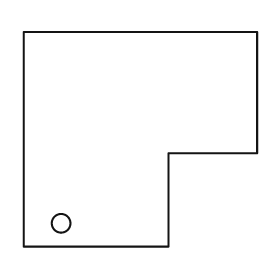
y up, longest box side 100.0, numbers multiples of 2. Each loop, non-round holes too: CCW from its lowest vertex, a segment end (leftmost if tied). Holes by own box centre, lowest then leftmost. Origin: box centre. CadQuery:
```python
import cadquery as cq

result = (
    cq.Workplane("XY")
    .moveTo(-50.0, -46.0)
    .lineTo(12.0, -46.0)
    .lineTo(12.0, -6.0)
    .lineTo(50.0, -6.0)
    .lineTo(50.0, 46.0)
    .lineTo(-50.0, 46.0)
    .close()
    .moveTo(-34.0, -36.0)
    .circle(4.0)
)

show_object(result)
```